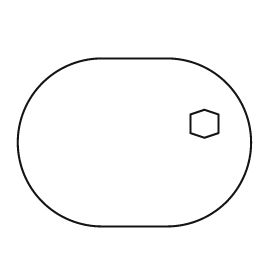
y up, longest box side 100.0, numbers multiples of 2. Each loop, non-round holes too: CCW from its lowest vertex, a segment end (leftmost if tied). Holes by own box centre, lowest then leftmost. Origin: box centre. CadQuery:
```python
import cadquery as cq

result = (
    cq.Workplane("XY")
    .moveTo(-14.0, -36.0)
    .lineTo(14.0, -36.0)
    .threePointArc((50.0, 0.0), (14.0, 36.0))
    .lineTo(-14.0, 36.0)
    .threePointArc((-50.0, 0.0), (-14.0, -36.0))
    .close()
    .moveTo(30.0, 2.0)
    .lineTo(36.0, 4.0)
    .lineTo(36.0, 12.0)
    .lineTo(30.0, 14.0)
    .lineTo(24.0, 12.0)
    .lineTo(24.0, 4.0)
    .close()
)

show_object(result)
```